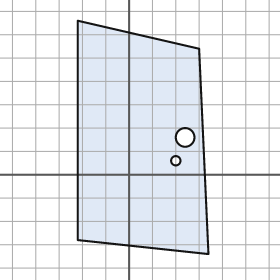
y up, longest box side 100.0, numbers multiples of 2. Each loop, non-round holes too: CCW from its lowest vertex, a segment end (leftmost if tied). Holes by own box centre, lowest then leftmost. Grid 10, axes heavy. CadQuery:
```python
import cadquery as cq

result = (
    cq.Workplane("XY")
    .moveTo(34.0, -34.0)
    .lineTo(30.0, 54.0)
    .lineTo(-22.0, 66.0)
    .lineTo(-22.0, -28.0)
    .close()
    .moveTo(20.0, 6.0)
    .circle(2.0)
    .moveTo(24.0, 16.0)
    .circle(4.0)
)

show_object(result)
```